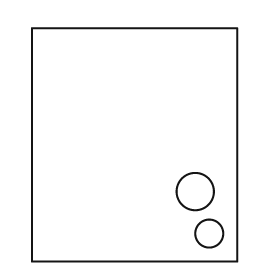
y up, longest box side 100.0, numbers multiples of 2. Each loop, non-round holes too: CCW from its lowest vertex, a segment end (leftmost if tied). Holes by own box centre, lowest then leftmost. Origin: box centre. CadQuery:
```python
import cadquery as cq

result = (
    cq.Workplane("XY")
    .moveTo(-44.0, -50.0)
    .lineTo(44.0, -50.0)
    .lineTo(44.0, 50.0)
    .lineTo(-44.0, 50.0)
    .close()
    .moveTo(32.0, -38.0)
    .circle(6.0)
    .moveTo(26.0, -20.0)
    .circle(8.0)
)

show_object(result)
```